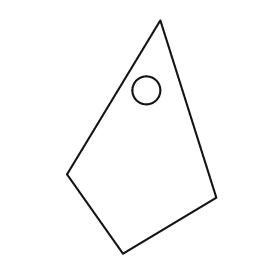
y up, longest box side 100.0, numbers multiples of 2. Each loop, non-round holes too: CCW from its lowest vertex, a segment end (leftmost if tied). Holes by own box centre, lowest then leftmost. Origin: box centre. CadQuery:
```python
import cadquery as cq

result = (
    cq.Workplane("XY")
    .moveTo(-8.0, -50.0)
    .lineTo(32.0, -26.0)
    .lineTo(8.0, 50.0)
    .lineTo(-32.0, -16.0)
    .close()
    .moveTo(2.0, 20.0)
    .circle(6.0)
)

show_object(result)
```